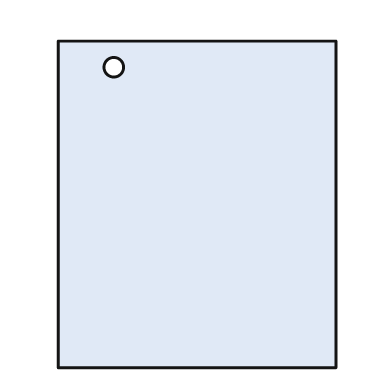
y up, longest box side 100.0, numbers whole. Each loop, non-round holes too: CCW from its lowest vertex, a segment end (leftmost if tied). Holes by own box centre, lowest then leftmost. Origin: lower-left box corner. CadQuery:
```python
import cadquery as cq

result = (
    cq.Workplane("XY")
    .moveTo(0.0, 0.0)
    .lineTo(85.0, 0.0)
    .lineTo(85.0, 100.0)
    .lineTo(0.0, 100.0)
    .close()
    .moveTo(17.0, 92.0)
    .circle(3.0)
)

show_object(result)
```